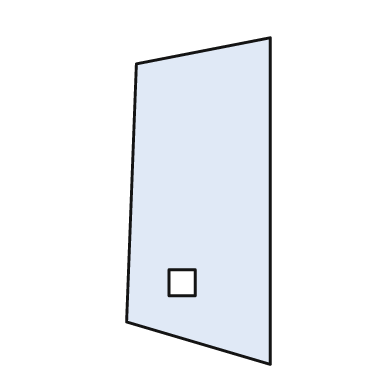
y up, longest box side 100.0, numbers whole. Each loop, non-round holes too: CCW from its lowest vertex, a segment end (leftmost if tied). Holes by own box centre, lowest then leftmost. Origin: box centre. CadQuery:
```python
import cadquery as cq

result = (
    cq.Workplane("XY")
    .moveTo(22.0, -50.0)
    .lineTo(22.0, 50.0)
    .lineTo(-19.0, 42.0)
    .lineTo(-22.0, -37.0)
    .close()
    .moveTo(-9.0, -29.0)
    .lineTo(-1.0, -29.0)
    .lineTo(-1.0, -21.0)
    .lineTo(-9.0, -21.0)
    .close()
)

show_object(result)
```